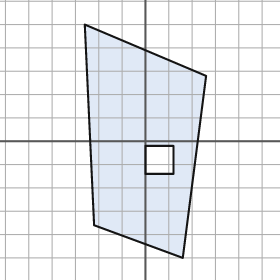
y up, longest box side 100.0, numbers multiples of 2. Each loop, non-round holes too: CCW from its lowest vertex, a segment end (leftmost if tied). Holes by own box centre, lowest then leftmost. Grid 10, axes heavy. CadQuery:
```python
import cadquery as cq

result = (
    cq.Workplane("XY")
    .moveTo(16.0, -50.0)
    .lineTo(26.0, 28.0)
    .lineTo(-26.0, 50.0)
    .lineTo(-22.0, -36.0)
    .close()
    .moveTo(0.0, -14.0)
    .lineTo(12.0, -14.0)
    .lineTo(12.0, -2.0)
    .lineTo(0.0, -2.0)
    .close()
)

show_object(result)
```